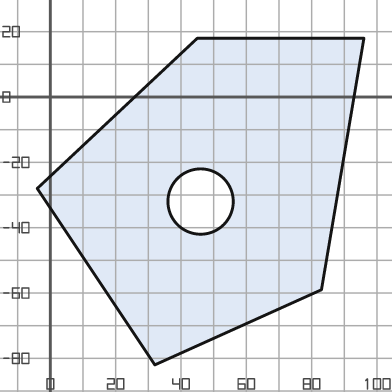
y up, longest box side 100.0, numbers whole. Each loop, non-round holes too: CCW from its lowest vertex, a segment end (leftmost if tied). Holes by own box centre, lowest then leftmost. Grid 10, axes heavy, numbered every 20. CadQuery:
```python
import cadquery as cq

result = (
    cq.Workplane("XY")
    .moveTo(32.0, -82.0)
    .lineTo(83.0, -59.0)
    .lineTo(96.0, 18.0)
    .lineTo(45.0, 18.0)
    .lineTo(-4.0, -28.0)
    .close()
    .moveTo(46.0, -32.0)
    .circle(10.0)
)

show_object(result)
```